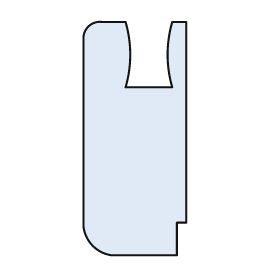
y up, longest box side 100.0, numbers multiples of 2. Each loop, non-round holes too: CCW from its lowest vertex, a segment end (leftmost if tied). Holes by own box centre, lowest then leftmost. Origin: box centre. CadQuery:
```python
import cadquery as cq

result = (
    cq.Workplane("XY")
    .moveTo(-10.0, -50.0)
    .lineTo(18.0, -50.0)
    .lineTo(18.0, -36.0)
    .lineTo(22.0, -36.0)
    .lineTo(22.0, 50.0)
    .lineTo(16.0, 50.0)
    .threePointArc((14.0, 36.0), (16.0, 22.0))
    .lineTo(-4.0, 22.0)
    .threePointArc((-2.0, 36.0), (-4.0, 50.0))
    .lineTo(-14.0, 50.0)
    .threePointArc((-20.0, 48.0), (-22.0, 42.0))
    .lineTo(-22.0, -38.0)
    .threePointArc((-18.0, -46.0), (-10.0, -50.0))
    .close()
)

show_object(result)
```